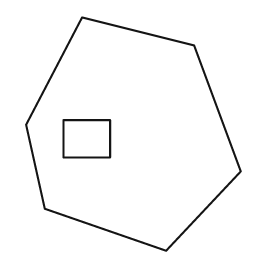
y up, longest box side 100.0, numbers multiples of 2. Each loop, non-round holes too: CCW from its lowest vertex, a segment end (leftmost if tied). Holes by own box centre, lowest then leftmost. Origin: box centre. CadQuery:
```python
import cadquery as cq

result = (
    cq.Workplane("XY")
    .moveTo(14.0, -50.0)
    .lineTo(46.0, -16.0)
    .lineTo(26.0, 38.0)
    .lineTo(-22.0, 50.0)
    .lineTo(-46.0, 4.0)
    .lineTo(-38.0, -32.0)
    .close()
    .moveTo(-30.0, -10.0)
    .lineTo(-10.0, -10.0)
    .lineTo(-10.0, 6.0)
    .lineTo(-30.0, 6.0)
    .close()
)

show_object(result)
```